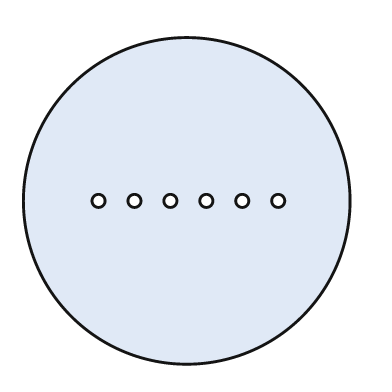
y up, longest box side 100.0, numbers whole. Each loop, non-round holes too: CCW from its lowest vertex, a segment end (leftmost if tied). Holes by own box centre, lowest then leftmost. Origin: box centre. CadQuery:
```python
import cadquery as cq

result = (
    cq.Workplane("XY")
    .moveTo(0.0, 0.0)
    .circle(50.0)
    .moveTo(-27.0, 0.0)
    .circle(2.0)
    .moveTo(-16.0, 0.0)
    .circle(2.0)
    .moveTo(-5.0, 0.0)
    .circle(2.0)
    .moveTo(6.0, 0.0)
    .circle(2.0)
    .moveTo(17.0, 0.0)
    .circle(2.0)
    .moveTo(28.0, 0.0)
    .circle(2.0)
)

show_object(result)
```